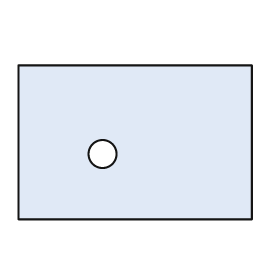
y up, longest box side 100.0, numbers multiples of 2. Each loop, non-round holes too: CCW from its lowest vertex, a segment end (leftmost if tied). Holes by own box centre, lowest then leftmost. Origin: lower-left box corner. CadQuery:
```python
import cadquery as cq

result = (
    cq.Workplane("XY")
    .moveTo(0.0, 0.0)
    .lineTo(100.0, 0.0)
    .lineTo(100.0, 66.0)
    .lineTo(0.0, 66.0)
    .close()
    .moveTo(36.0, 28.0)
    .circle(6.0)
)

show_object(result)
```